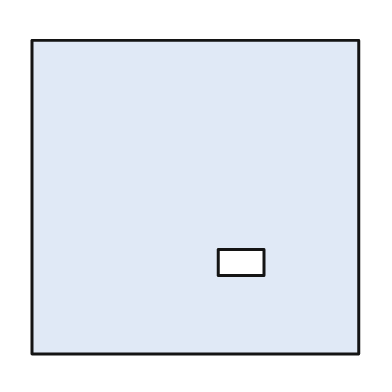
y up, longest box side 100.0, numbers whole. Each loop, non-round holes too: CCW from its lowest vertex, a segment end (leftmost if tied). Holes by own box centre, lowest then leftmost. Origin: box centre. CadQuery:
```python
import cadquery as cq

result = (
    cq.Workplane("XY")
    .moveTo(-50.0, -48.0)
    .lineTo(50.0, -48.0)
    .lineTo(50.0, 48.0)
    .lineTo(-50.0, 48.0)
    .close()
    .moveTo(7.0, -24.0)
    .lineTo(21.0, -24.0)
    .lineTo(21.0, -16.0)
    .lineTo(7.0, -16.0)
    .close()
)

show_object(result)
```